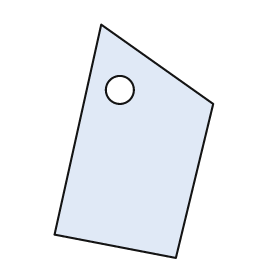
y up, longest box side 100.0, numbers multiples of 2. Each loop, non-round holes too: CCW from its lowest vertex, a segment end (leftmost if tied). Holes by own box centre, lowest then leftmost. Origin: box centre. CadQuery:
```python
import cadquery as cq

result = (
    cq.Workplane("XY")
    .moveTo(18.0, -50.0)
    .lineTo(34.0, 16.0)
    .lineTo(-14.0, 50.0)
    .lineTo(-34.0, -40.0)
    .close()
    .moveTo(-6.0, 22.0)
    .circle(6.0)
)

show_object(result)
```